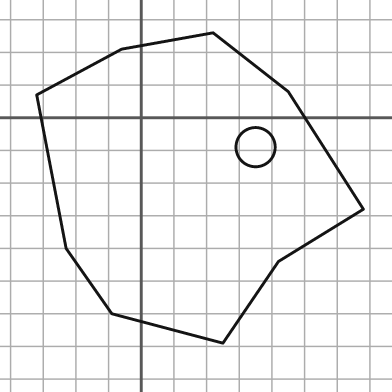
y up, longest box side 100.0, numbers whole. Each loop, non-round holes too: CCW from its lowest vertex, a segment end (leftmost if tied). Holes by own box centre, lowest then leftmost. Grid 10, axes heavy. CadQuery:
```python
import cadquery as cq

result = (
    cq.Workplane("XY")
    .moveTo(25.0, -69.0)
    .lineTo(42.0, -44.0)
    .lineTo(68.0, -28.0)
    .lineTo(45.0, 8.0)
    .lineTo(22.0, 26.0)
    .lineTo(-6.0, 21.0)
    .lineTo(-32.0, 7.0)
    .lineTo(-23.0, -40.0)
    .lineTo(-9.0, -60.0)
    .close()
    .moveTo(35.0, -9.0)
    .circle(6.0)
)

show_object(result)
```